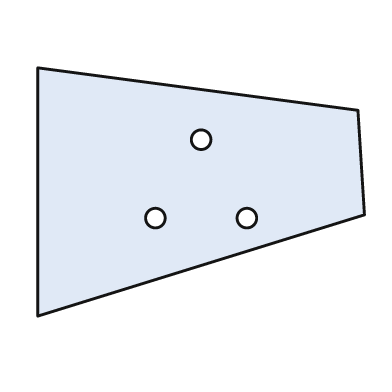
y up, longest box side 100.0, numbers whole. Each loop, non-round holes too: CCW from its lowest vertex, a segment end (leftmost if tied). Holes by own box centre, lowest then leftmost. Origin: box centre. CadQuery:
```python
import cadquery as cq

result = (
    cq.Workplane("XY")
    .moveTo(-50.0, -38.0)
    .lineTo(50.0, -7.0)
    .lineTo(48.0, 25.0)
    .lineTo(-50.0, 38.0)
    .close()
    .moveTo(-14.0, -8.0)
    .circle(3.0)
    .moveTo(14.0, -8.0)
    .circle(3.0)
    .moveTo(0.0, 16.0)
    .circle(3.0)
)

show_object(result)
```